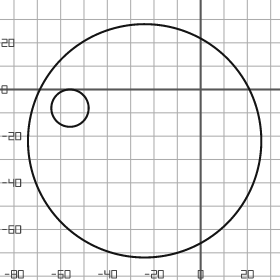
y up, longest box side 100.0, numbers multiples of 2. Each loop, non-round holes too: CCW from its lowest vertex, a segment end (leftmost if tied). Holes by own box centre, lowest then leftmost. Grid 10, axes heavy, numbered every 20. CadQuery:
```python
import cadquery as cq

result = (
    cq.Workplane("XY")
    .moveTo(-24.0, -22.0)
    .circle(50.0)
    .moveTo(-56.0, -8.0)
    .circle(8.0)
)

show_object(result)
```